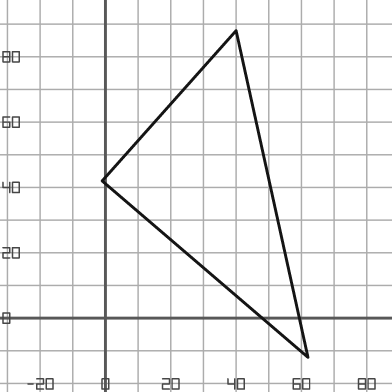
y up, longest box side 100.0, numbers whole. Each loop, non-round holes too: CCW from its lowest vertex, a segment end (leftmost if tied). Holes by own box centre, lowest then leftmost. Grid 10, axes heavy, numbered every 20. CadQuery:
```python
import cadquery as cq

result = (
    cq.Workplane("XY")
    .moveTo(62.0, -12.0)
    .lineTo(40.0, 88.0)
    .lineTo(-1.0, 42.0)
    .close()
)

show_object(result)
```